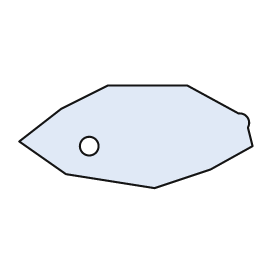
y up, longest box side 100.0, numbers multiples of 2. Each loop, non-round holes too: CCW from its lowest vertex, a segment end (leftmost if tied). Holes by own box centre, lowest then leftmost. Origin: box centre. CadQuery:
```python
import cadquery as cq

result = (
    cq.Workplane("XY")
    .moveTo(8.0, -22.0)
    .lineTo(32.0, -14.0)
    .lineTo(50.0, -4.0)
    .lineTo(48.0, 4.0)
    .threePointArc((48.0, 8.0), (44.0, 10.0))
    .lineTo(22.0, 22.0)
    .lineTo(-12.0, 22.0)
    .lineTo(-32.0, 12.0)
    .lineTo(-50.0, -2.0)
    .lineTo(-30.0, -16.0)
    .close()
    .moveTo(-20.0, -4.0)
    .circle(4.0)
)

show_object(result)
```